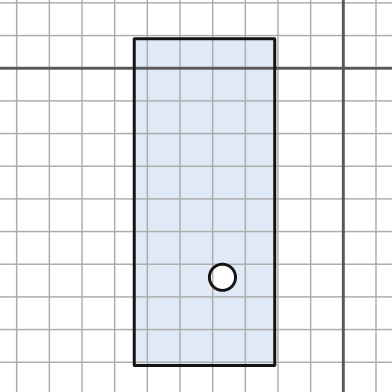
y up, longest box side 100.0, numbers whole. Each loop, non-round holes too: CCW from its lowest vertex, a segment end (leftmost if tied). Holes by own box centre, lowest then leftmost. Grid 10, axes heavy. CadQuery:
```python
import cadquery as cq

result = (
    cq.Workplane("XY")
    .moveTo(-64.0, -91.0)
    .lineTo(-21.0, -91.0)
    .lineTo(-21.0, 9.0)
    .lineTo(-64.0, 9.0)
    .close()
    .moveTo(-37.0, -64.0)
    .circle(4.0)
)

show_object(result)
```